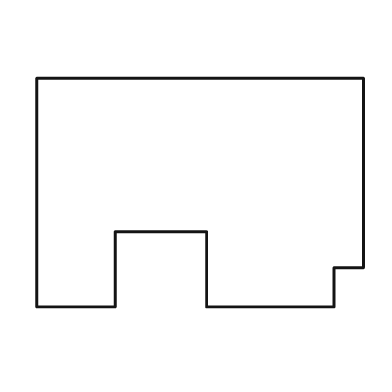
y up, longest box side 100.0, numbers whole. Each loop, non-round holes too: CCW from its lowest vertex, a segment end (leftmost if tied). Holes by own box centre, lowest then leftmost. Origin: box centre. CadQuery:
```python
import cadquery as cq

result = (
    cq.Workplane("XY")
    .moveTo(-50.0, -35.0)
    .lineTo(-26.0, -35.0)
    .lineTo(-26.0, -12.0)
    .lineTo(2.0, -12.0)
    .lineTo(2.0, -35.0)
    .lineTo(41.0, -35.0)
    .lineTo(41.0, -23.0)
    .lineTo(50.0, -23.0)
    .lineTo(50.0, 35.0)
    .lineTo(-50.0, 35.0)
    .close()
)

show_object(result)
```